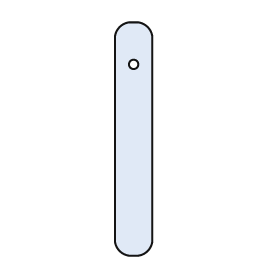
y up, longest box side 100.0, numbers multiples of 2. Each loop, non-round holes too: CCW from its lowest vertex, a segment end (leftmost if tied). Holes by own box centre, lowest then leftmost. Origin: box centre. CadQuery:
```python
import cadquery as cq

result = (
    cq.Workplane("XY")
    .moveTo(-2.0, -50.0)
    .lineTo(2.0, -50.0)
    .threePointArc((6.0, -48.0), (8.0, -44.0))
    .lineTo(8.0, 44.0)
    .threePointArc((6.0, 48.0), (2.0, 50.0))
    .lineTo(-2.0, 50.0)
    .threePointArc((-6.0, 48.0), (-8.0, 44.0))
    .lineTo(-8.0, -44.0)
    .threePointArc((-6.0, -48.0), (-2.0, -50.0))
    .close()
    .moveTo(0.0, 32.0)
    .circle(2.0)
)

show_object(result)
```